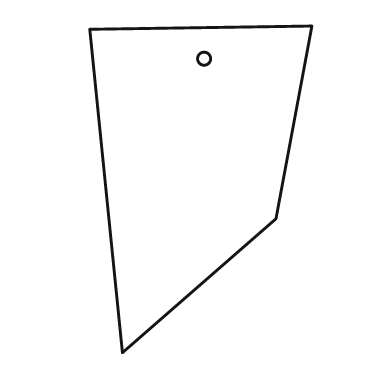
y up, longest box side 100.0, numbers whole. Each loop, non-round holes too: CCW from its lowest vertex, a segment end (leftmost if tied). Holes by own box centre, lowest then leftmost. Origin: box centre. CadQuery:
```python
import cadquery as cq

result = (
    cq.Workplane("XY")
    .moveTo(-24.0, -50.0)
    .lineTo(23.0, -9.0)
    .lineTo(34.0, 50.0)
    .lineTo(-34.0, 49.0)
    .close()
    .moveTo(1.0, 40.0)
    .circle(2.0)
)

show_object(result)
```